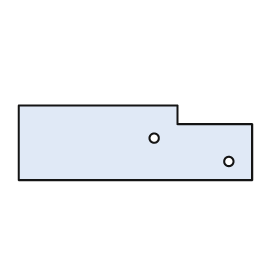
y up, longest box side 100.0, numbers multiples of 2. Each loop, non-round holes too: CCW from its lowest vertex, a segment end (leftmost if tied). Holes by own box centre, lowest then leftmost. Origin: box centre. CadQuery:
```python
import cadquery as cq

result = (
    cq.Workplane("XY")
    .moveTo(-50.0, -16.0)
    .lineTo(50.0, -16.0)
    .lineTo(50.0, 8.0)
    .lineTo(18.0, 8.0)
    .lineTo(18.0, 16.0)
    .lineTo(-50.0, 16.0)
    .close()
    .moveTo(40.0, -8.0)
    .circle(2.0)
    .moveTo(8.0, 2.0)
    .circle(2.0)
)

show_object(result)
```